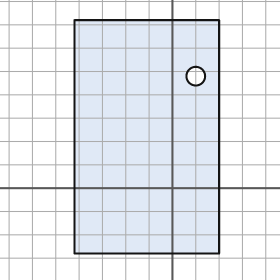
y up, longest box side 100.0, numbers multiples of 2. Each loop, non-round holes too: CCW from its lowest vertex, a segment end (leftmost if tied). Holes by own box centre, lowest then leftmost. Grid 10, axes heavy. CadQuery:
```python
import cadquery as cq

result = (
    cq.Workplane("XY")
    .moveTo(-42.0, -28.0)
    .lineTo(20.0, -28.0)
    .lineTo(20.0, 72.0)
    .lineTo(-42.0, 72.0)
    .close()
    .moveTo(10.0, 48.0)
    .circle(4.0)
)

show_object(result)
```